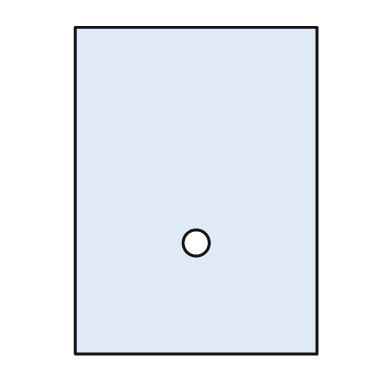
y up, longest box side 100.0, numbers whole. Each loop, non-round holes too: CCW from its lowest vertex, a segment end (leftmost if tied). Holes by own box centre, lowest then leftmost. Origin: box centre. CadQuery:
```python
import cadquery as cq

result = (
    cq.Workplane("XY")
    .moveTo(-37.0, -50.0)
    .lineTo(37.0, -50.0)
    .lineTo(37.0, 50.0)
    .lineTo(-37.0, 50.0)
    .close()
    .moveTo(0.0, -16.0)
    .circle(4.0)
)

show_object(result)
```